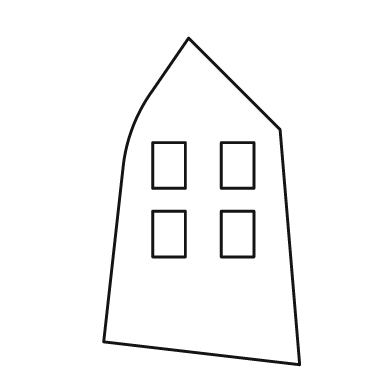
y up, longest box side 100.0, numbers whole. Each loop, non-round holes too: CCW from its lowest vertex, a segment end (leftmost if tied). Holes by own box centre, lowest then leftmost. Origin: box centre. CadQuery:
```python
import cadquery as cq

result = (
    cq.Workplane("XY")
    .moveTo(30.0, -50.0)
    .lineTo(24.0, 22.0)
    .lineTo(-4.0, 50.0)
    .lineTo(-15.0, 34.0)
    .threePointArc((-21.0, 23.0), (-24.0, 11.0))
    .lineTo(-30.0, -43.0)
    .close()
    .moveTo(-15.0, -17.0)
    .lineTo(-5.0, -17.0)
    .lineTo(-5.0, -3.0)
    .lineTo(-15.0, -3.0)
    .close()
    .moveTo(6.0, -17.0)
    .lineTo(16.0, -17.0)
    .lineTo(16.0, -3.0)
    .lineTo(6.0, -3.0)
    .close()
    .moveTo(-15.0, 4.0)
    .lineTo(-5.0, 4.0)
    .lineTo(-5.0, 18.0)
    .lineTo(-15.0, 18.0)
    .close()
    .moveTo(6.0, 4.0)
    .lineTo(16.0, 4.0)
    .lineTo(16.0, 18.0)
    .lineTo(6.0, 18.0)
    .close()
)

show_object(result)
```